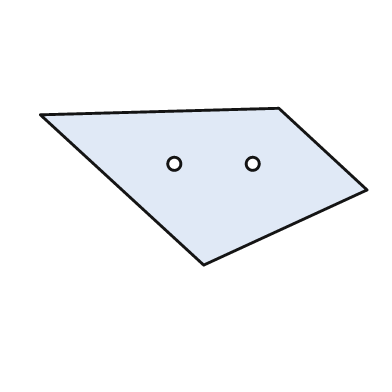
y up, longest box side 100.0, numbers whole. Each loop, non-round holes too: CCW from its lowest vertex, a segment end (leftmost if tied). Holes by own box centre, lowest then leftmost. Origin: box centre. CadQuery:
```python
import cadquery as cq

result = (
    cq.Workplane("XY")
    .moveTo(0.0, -24.0)
    .lineTo(50.0, -1.0)
    .lineTo(23.0, 24.0)
    .lineTo(-50.0, 22.0)
    .close()
    .moveTo(-9.0, 7.0)
    .circle(2.0)
    .moveTo(15.0, 7.0)
    .circle(2.0)
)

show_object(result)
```